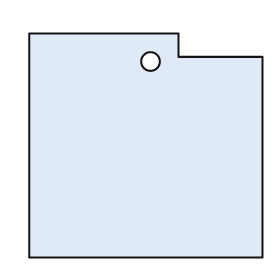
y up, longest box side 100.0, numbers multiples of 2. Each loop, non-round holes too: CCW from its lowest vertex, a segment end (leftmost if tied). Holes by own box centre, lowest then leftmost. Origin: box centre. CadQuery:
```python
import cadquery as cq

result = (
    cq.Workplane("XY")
    .moveTo(-50.0, -48.0)
    .lineTo(50.0, -48.0)
    .lineTo(50.0, 38.0)
    .lineTo(14.0, 38.0)
    .lineTo(14.0, 48.0)
    .lineTo(-50.0, 48.0)
    .close()
    .moveTo(2.0, 36.0)
    .circle(4.0)
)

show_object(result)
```